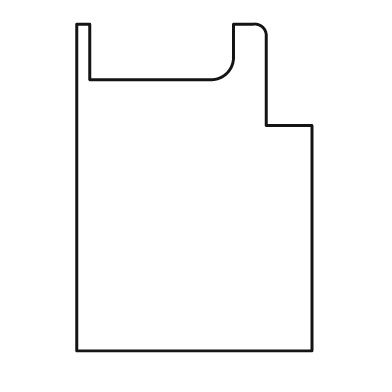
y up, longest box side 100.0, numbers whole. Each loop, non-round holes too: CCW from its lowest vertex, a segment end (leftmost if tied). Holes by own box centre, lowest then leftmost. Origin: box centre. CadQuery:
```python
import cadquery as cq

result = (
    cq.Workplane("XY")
    .moveTo(-36.0, -50.0)
    .lineTo(36.0, -50.0)
    .lineTo(36.0, 19.0)
    .lineTo(22.0, 19.0)
    .lineTo(22.0, 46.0)
    .threePointArc((21.0, 49.0), (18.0, 50.0))
    .lineTo(12.0, 50.0)
    .lineTo(12.0, 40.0)
    .threePointArc((10.0, 35.0), (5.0, 33.0))
    .lineTo(-32.0, 33.0)
    .lineTo(-32.0, 50.0)
    .lineTo(-36.0, 50.0)
    .close()
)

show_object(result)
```